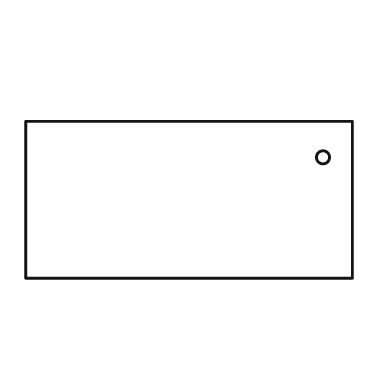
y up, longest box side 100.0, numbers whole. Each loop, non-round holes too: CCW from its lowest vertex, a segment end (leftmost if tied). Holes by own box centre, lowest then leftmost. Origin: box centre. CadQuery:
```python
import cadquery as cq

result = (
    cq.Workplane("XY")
    .moveTo(-50.0, -24.0)
    .lineTo(50.0, -24.0)
    .lineTo(50.0, 24.0)
    .lineTo(-50.0, 24.0)
    .close()
    .moveTo(41.0, 13.0)
    .circle(2.0)
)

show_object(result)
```